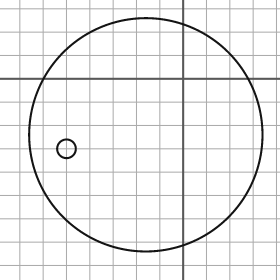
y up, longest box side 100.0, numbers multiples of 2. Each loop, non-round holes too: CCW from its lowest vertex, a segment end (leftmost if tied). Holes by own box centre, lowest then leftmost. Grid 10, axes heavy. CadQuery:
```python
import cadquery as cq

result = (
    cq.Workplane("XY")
    .moveTo(-16.0, -24.0)
    .circle(50.0)
    .moveTo(-50.0, -30.0)
    .circle(4.0)
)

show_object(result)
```